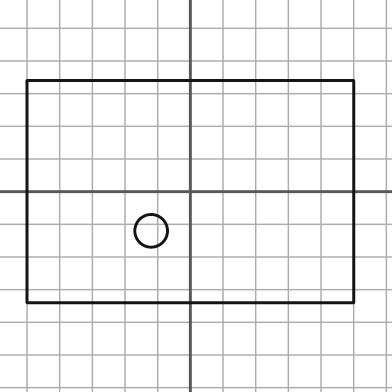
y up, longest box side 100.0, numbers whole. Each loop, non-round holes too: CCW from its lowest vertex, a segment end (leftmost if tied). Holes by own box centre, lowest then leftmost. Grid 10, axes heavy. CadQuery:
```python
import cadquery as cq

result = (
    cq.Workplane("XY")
    .moveTo(-50.0, -34.0)
    .lineTo(50.0, -34.0)
    .lineTo(50.0, 34.0)
    .lineTo(-50.0, 34.0)
    .close()
    .moveTo(-12.0, -12.0)
    .circle(5.0)
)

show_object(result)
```